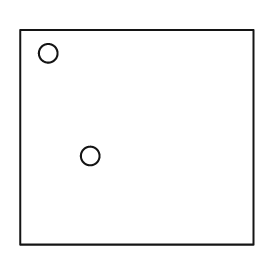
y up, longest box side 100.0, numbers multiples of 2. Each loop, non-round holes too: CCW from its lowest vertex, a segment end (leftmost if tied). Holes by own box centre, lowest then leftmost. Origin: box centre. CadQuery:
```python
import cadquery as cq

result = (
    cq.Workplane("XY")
    .moveTo(-50.0, -46.0)
    .lineTo(50.0, -46.0)
    .lineTo(50.0, 46.0)
    .lineTo(-50.0, 46.0)
    .close()
    .moveTo(-20.0, -8.0)
    .circle(4.0)
    .moveTo(-38.0, 36.0)
    .circle(4.0)
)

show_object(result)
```